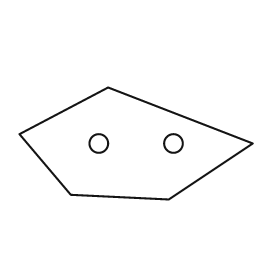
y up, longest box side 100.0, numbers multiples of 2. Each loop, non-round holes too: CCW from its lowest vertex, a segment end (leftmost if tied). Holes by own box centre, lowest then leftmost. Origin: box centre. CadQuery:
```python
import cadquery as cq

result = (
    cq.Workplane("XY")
    .moveTo(14.0, -24.0)
    .lineTo(50.0, 0.0)
    .lineTo(-12.0, 24.0)
    .lineTo(-50.0, 4.0)
    .lineTo(-28.0, -22.0)
    .close()
    .moveTo(-16.0, 0.0)
    .circle(4.0)
    .moveTo(16.0, 0.0)
    .circle(4.0)
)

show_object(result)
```